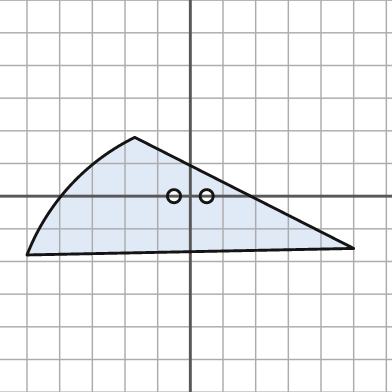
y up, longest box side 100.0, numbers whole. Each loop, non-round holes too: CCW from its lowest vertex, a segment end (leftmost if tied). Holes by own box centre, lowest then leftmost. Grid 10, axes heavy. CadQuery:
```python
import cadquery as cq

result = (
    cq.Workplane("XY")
    .moveTo(-50.0, -18.0)
    .lineTo(50.0, -16.0)
    .lineTo(-17.0, 18.0)
    .threePointArc((-37.0, 3.0), (-50.0, -18.0))
    .close()
    .moveTo(-5.0, 0.0)
    .circle(2.0)
    .moveTo(5.0, 0.0)
    .circle(2.0)
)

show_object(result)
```